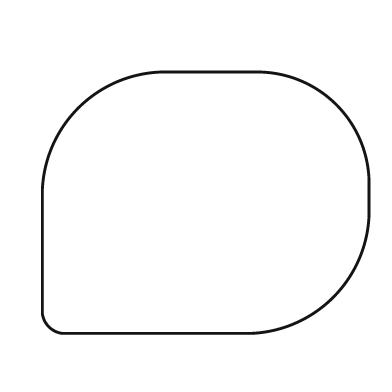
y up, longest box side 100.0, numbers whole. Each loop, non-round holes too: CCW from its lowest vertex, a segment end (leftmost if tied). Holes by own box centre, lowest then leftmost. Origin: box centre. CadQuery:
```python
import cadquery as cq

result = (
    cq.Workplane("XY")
    .moveTo(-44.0, -40.0)
    .lineTo(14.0, -40.0)
    .threePointArc((39.0, -29.0), (50.0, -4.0))
    .lineTo(50.0, 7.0)
    .threePointArc((40.0, 30.0), (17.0, 40.0))
    .lineTo(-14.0, 40.0)
    .threePointArc((-39.0, 29.0), (-50.0, 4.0))
    .lineTo(-50.0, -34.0)
    .threePointArc((-48.0, -38.0), (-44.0, -40.0))
    .close()
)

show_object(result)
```